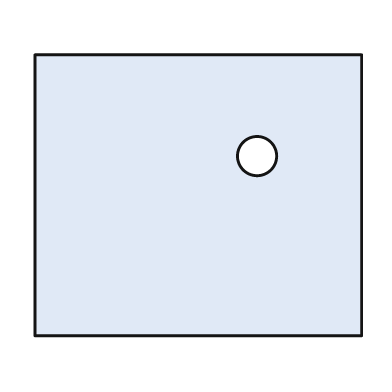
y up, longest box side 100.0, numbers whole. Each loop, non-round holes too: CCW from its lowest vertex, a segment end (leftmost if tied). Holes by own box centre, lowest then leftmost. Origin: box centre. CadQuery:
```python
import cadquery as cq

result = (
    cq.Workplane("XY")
    .moveTo(-50.0, -43.0)
    .lineTo(50.0, -43.0)
    .lineTo(50.0, 43.0)
    .lineTo(-50.0, 43.0)
    .close()
    .moveTo(18.0, 12.0)
    .circle(6.0)
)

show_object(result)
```